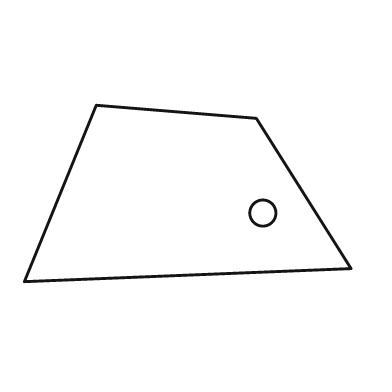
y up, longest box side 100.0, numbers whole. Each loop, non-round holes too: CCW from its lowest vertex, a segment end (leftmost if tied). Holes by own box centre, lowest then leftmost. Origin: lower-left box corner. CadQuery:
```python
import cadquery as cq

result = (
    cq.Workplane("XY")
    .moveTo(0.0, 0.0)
    .lineTo(100.0, 4.0)
    .lineTo(71.0, 50.0)
    .lineTo(22.0, 54.0)
    .close()
    .moveTo(73.0, 21.0)
    .circle(4.0)
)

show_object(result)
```